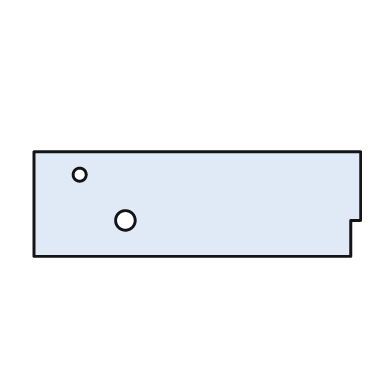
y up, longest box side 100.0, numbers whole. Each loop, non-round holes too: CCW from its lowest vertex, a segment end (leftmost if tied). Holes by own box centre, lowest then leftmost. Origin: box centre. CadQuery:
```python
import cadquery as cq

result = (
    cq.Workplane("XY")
    .moveTo(-50.0, -16.0)
    .lineTo(47.0, -16.0)
    .lineTo(47.0, -5.0)
    .lineTo(50.0, -5.0)
    .lineTo(50.0, 16.0)
    .lineTo(-50.0, 16.0)
    .close()
    .moveTo(-22.0, -5.0)
    .circle(3.0)
    .moveTo(-36.0, 9.0)
    .circle(2.0)
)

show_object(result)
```